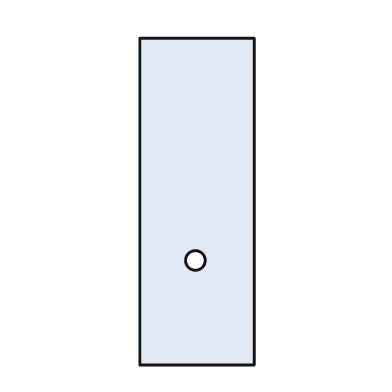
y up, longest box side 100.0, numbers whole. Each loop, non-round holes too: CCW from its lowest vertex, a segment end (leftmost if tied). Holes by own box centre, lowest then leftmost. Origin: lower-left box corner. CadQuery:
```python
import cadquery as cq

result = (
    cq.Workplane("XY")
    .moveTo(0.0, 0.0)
    .lineTo(35.0, 0.0)
    .lineTo(35.0, 100.0)
    .lineTo(0.0, 100.0)
    .close()
    .moveTo(17.0, 32.0)
    .circle(3.0)
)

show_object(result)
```